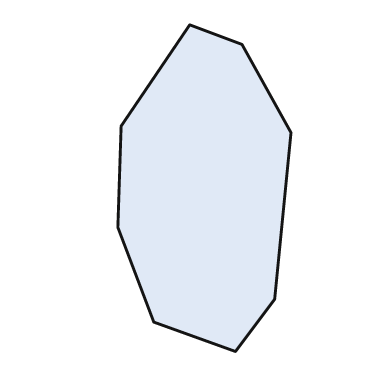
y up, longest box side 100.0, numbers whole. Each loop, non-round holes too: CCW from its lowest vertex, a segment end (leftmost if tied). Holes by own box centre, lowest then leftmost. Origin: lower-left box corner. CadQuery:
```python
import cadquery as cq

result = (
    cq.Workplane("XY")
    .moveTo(36.0, 0.0)
    .lineTo(48.0, 16.0)
    .lineTo(53.0, 67.0)
    .lineTo(38.0, 94.0)
    .lineTo(22.0, 100.0)
    .lineTo(1.0, 69.0)
    .lineTo(0.0, 38.0)
    .lineTo(11.0, 9.0)
    .close()
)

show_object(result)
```